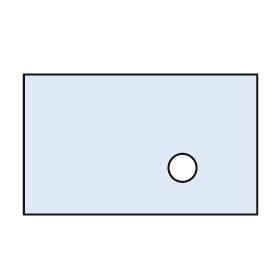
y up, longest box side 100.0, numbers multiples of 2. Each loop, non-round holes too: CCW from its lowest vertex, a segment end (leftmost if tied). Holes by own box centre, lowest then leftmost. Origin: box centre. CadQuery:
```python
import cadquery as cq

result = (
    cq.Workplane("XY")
    .moveTo(-50.0, -30.0)
    .lineTo(50.0, -30.0)
    .lineTo(50.0, 30.0)
    .lineTo(-50.0, 30.0)
    .close()
    .moveTo(18.0, -10.0)
    .circle(6.0)
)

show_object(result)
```